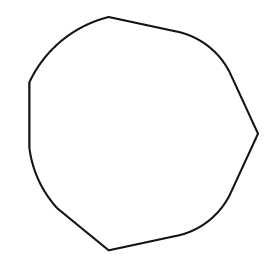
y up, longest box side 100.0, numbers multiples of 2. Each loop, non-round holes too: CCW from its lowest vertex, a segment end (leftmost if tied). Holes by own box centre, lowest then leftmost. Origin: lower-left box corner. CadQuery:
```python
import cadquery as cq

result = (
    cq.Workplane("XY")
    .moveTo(34.0, 0.0)
    .lineTo(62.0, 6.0)
    .threePointArc((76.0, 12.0), (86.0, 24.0))
    .lineTo(98.0, 50.0)
    .lineTo(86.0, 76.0)
    .threePointArc((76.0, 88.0), (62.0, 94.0))
    .lineTo(34.0, 100.0)
    .threePointArc((14.0, 90.0), (0.0, 72.0))
    .lineTo(0.0, 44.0)
    .threePointArc((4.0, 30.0), (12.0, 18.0))
    .close()
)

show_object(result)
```